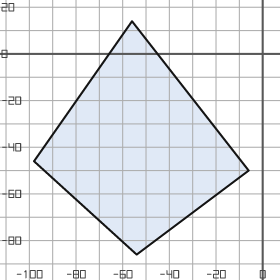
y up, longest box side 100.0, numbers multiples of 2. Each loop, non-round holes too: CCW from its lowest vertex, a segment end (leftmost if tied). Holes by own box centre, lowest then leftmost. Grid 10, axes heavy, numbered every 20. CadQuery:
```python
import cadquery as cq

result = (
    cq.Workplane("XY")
    .moveTo(-54.0, -86.0)
    .lineTo(-6.0, -50.0)
    .lineTo(-56.0, 14.0)
    .lineTo(-98.0, -46.0)
    .close()
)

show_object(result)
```